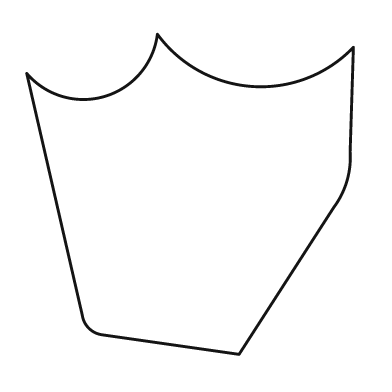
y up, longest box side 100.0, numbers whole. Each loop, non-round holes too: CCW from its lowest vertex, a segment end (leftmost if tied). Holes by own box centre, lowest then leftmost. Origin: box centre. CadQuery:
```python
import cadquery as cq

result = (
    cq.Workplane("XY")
    .moveTo(15.0, -49.0)
    .lineTo(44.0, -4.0)
    .threePointArc((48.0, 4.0), (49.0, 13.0))
    .lineTo(50.0, 45.0)
    .threePointArc((19.0, 33.0), (-10.0, 49.0))
    .threePointArc((-26.0, 30.0), (-50.0, 37.0))
    .lineTo(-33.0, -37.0)
    .threePointArc((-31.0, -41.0), (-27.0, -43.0))
    .close()
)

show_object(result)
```